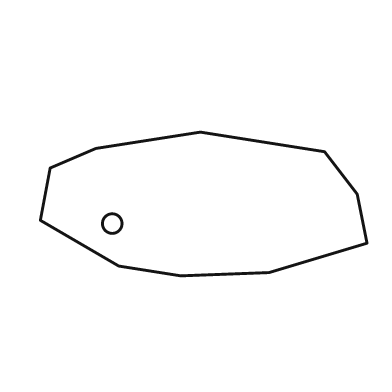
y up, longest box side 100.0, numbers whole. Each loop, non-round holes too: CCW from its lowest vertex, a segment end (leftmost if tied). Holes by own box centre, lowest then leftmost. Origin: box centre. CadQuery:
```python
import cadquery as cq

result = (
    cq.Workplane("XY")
    .moveTo(-7.0, -22.0)
    .lineTo(20.0, -21.0)
    .lineTo(50.0, -12.0)
    .lineTo(47.0, 3.0)
    .lineTo(37.0, 16.0)
    .lineTo(-1.0, 22.0)
    .lineTo(-33.0, 17.0)
    .lineTo(-47.0, 11.0)
    .lineTo(-50.0, -5.0)
    .lineTo(-26.0, -19.0)
    .close()
    .moveTo(-28.0, -6.0)
    .circle(3.0)
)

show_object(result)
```